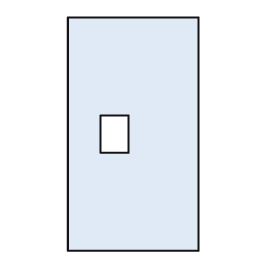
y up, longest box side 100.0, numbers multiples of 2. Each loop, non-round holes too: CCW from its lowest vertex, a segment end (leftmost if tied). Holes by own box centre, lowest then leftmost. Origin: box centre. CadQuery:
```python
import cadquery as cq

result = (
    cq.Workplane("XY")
    .moveTo(-28.0, -50.0)
    .lineTo(28.0, -50.0)
    .lineTo(28.0, 50.0)
    .lineTo(-28.0, 50.0)
    .close()
    .moveTo(-14.0, -8.0)
    .lineTo(-2.0, -8.0)
    .lineTo(-2.0, 8.0)
    .lineTo(-14.0, 8.0)
    .close()
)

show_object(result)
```